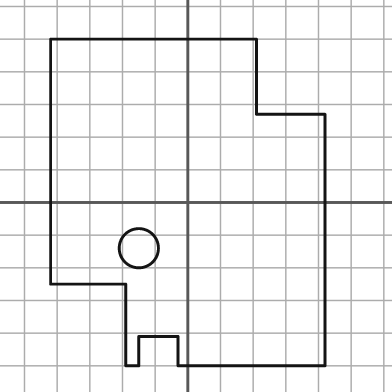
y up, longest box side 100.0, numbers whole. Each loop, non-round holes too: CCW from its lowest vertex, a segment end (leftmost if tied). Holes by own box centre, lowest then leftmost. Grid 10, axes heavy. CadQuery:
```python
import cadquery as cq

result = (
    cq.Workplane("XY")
    .moveTo(-19.0, -50.0)
    .lineTo(-15.0, -50.0)
    .lineTo(-15.0, -41.0)
    .lineTo(-3.0, -41.0)
    .lineTo(-3.0, -50.0)
    .lineTo(42.0, -50.0)
    .lineTo(42.0, 27.0)
    .lineTo(21.0, 27.0)
    .lineTo(21.0, 50.0)
    .lineTo(-42.0, 50.0)
    .lineTo(-42.0, -25.0)
    .lineTo(-19.0, -25.0)
    .close()
    .moveTo(-15.0, -14.0)
    .circle(6.0)
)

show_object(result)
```